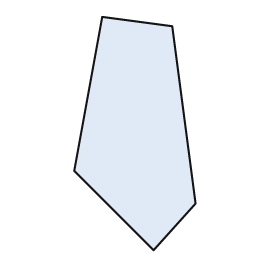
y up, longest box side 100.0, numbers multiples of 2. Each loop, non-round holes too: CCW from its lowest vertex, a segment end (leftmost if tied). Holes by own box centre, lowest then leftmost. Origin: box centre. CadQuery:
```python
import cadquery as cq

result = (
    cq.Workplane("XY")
    .moveTo(8.0, -50.0)
    .lineTo(26.0, -30.0)
    .lineTo(16.0, 46.0)
    .lineTo(-14.0, 50.0)
    .lineTo(-26.0, -16.0)
    .close()
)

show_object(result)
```